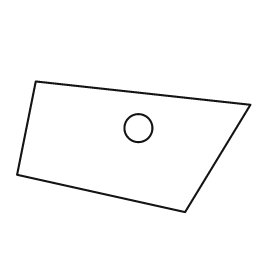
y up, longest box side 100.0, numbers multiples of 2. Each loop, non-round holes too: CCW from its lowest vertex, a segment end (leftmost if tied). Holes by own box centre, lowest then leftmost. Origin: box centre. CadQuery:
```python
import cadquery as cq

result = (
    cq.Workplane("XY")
    .moveTo(22.0, -28.0)
    .lineTo(50.0, 18.0)
    .lineTo(-42.0, 28.0)
    .lineTo(-50.0, -12.0)
    .close()
    .moveTo(2.0, 8.0)
    .circle(6.0)
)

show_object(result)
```